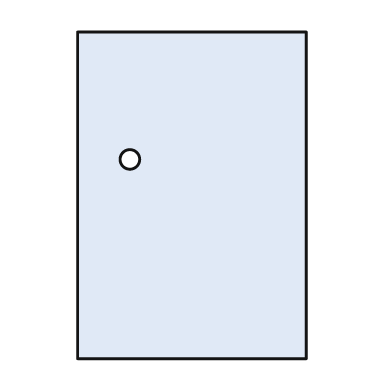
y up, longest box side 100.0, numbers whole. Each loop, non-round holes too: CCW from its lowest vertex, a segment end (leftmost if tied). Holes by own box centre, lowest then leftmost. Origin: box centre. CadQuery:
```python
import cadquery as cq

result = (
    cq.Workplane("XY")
    .moveTo(-35.0, -50.0)
    .lineTo(35.0, -50.0)
    .lineTo(35.0, 50.0)
    .lineTo(-35.0, 50.0)
    .close()
    .moveTo(-19.0, 11.0)
    .circle(3.0)
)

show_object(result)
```